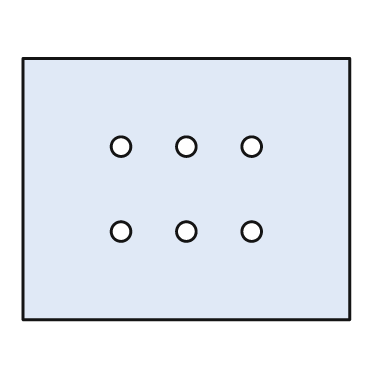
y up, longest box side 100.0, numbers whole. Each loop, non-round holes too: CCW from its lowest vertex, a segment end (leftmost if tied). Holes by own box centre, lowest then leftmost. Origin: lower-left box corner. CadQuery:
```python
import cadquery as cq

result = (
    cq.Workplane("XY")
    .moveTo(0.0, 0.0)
    .lineTo(100.0, 0.0)
    .lineTo(100.0, 80.0)
    .lineTo(0.0, 80.0)
    .close()
    .moveTo(30.0, 27.0)
    .circle(3.0)
    .moveTo(50.0, 27.0)
    .circle(3.0)
    .moveTo(70.0, 27.0)
    .circle(3.0)
    .moveTo(30.0, 53.0)
    .circle(3.0)
    .moveTo(50.0, 53.0)
    .circle(3.0)
    .moveTo(70.0, 53.0)
    .circle(3.0)
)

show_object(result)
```